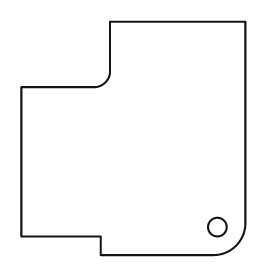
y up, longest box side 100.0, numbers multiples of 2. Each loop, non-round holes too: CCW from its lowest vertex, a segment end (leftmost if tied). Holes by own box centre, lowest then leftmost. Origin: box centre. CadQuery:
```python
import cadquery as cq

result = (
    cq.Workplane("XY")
    .moveTo(-14.0, -50.0)
    .lineTo(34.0, -50.0)
    .threePointArc((44.0, -46.0), (48.0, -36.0))
    .lineTo(48.0, 50.0)
    .lineTo(-10.0, 50.0)
    .lineTo(-10.0, 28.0)
    .threePointArc((-12.0, 24.0), (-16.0, 22.0))
    .lineTo(-48.0, 22.0)
    .lineTo(-48.0, -42.0)
    .lineTo(-14.0, -42.0)
    .close()
    .moveTo(36.0, -38.0)
    .circle(4.0)
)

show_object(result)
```